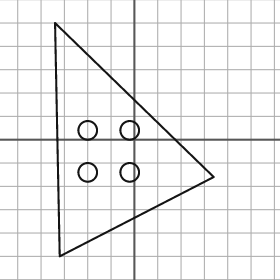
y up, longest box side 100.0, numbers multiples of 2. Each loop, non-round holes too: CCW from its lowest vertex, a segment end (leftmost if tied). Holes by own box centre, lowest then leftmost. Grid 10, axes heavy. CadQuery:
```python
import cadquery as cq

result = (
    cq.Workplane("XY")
    .moveTo(-32.0, -50.0)
    .lineTo(34.0, -16.0)
    .lineTo(-34.0, 50.0)
    .close()
    .moveTo(-20.0, -14.0)
    .circle(4.0)
    .moveTo(-2.0, -14.0)
    .circle(4.0)
    .moveTo(-20.0, 4.0)
    .circle(4.0)
    .moveTo(-2.0, 4.0)
    .circle(4.0)
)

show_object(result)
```